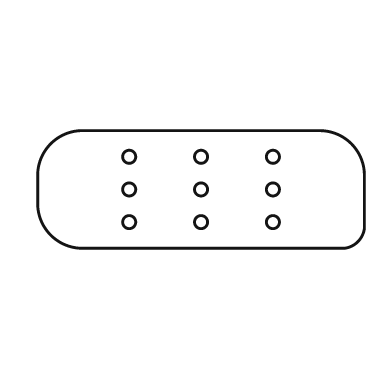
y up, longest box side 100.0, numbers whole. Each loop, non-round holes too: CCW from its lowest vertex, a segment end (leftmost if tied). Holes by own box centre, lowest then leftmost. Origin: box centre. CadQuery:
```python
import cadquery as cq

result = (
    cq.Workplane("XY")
    .moveTo(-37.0, -18.0)
    .lineTo(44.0, -18.0)
    .threePointArc((48.0, -16.0), (50.0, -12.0))
    .lineTo(50.0, 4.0)
    .threePointArc((46.0, 14.0), (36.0, 18.0))
    .lineTo(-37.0, 18.0)
    .threePointArc((-46.0, 14.0), (-50.0, 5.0))
    .lineTo(-50.0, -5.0)
    .threePointArc((-46.0, -14.0), (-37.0, -18.0))
    .close()
    .moveTo(-22.0, -10.0)
    .circle(2.0)
    .moveTo(0.0, -10.0)
    .circle(2.0)
    .moveTo(22.0, -10.0)
    .circle(2.0)
    .moveTo(-22.0, 0.0)
    .circle(2.0)
    .moveTo(0.0, 0.0)
    .circle(2.0)
    .moveTo(22.0, 0.0)
    .circle(2.0)
    .moveTo(-22.0, 10.0)
    .circle(2.0)
    .moveTo(0.0, 10.0)
    .circle(2.0)
    .moveTo(22.0, 10.0)
    .circle(2.0)
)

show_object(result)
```